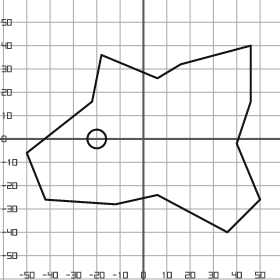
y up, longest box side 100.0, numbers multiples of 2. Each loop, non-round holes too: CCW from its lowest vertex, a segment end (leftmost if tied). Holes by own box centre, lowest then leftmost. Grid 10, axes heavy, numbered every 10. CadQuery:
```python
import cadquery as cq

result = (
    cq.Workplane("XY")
    .moveTo(36.0, -40.0)
    .lineTo(50.0, -26.0)
    .lineTo(40.0, -2.0)
    .lineTo(46.0, 16.0)
    .lineTo(46.0, 40.0)
    .lineTo(16.0, 32.0)
    .lineTo(6.0, 26.0)
    .lineTo(-18.0, 36.0)
    .lineTo(-22.0, 16.0)
    .lineTo(-50.0, -6.0)
    .lineTo(-42.0, -26.0)
    .lineTo(-12.0, -28.0)
    .lineTo(6.0, -24.0)
    .close()
    .moveTo(-20.0, 0.0)
    .circle(4.0)
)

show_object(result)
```